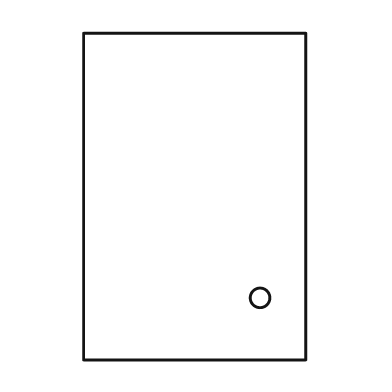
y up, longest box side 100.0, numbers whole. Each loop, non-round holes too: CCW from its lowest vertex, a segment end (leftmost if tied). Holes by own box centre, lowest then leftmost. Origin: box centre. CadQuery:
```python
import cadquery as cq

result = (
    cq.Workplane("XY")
    .moveTo(-34.0, -50.0)
    .lineTo(34.0, -50.0)
    .lineTo(34.0, 50.0)
    .lineTo(-34.0, 50.0)
    .close()
    .moveTo(20.0, -31.0)
    .circle(3.0)
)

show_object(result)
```